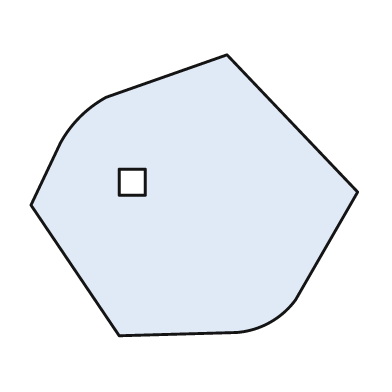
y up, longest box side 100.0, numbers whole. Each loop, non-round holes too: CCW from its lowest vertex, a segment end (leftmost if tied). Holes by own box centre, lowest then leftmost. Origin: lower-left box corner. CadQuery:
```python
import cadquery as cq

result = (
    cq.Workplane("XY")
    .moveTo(27.0, 0.0)
    .lineTo(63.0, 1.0)
    .threePointArc((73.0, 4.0), (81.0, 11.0))
    .lineTo(100.0, 44.0)
    .lineTo(60.0, 86.0)
    .lineTo(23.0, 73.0)
    .threePointArc((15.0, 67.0), (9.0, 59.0))
    .lineTo(0.0, 40.0)
    .close()
    .moveTo(27.0, 43.0)
    .lineTo(35.0, 43.0)
    .lineTo(35.0, 51.0)
    .lineTo(27.0, 51.0)
    .close()
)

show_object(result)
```